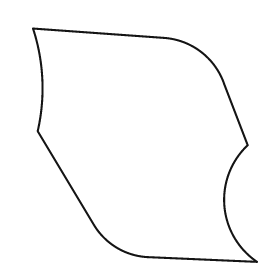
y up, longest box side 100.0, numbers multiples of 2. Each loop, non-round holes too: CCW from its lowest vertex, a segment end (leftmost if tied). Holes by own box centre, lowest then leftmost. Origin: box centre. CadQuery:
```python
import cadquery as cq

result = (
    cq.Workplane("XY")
    .moveTo(48.0, -50.0)
    .threePointArc((34.0, -26.0), (44.0, 0.0))
    .lineTo(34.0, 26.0)
    .threePointArc((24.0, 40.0), (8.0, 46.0))
    .lineTo(-48.0, 50.0)
    .threePointArc((-44.0, 28.0), (-46.0, 6.0))
    .lineTo(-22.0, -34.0)
    .threePointArc((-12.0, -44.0), (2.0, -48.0))
    .close()
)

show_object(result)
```